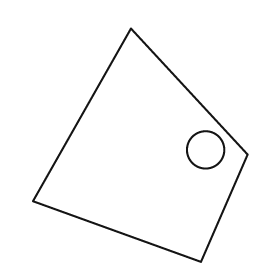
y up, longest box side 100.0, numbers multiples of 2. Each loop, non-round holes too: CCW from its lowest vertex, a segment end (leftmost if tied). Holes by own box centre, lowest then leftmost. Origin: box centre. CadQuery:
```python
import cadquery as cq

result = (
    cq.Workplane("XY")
    .moveTo(26.0, -50.0)
    .lineTo(46.0, -4.0)
    .lineTo(-4.0, 50.0)
    .lineTo(-46.0, -24.0)
    .close()
    .moveTo(28.0, -2.0)
    .circle(8.0)
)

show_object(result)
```